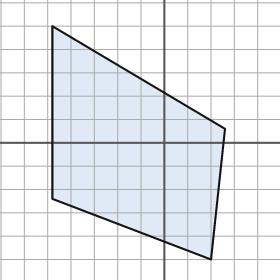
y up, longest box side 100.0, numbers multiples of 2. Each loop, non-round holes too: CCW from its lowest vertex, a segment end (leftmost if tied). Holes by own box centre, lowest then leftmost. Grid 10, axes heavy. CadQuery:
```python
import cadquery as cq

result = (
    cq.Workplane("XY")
    .moveTo(20.0, -50.0)
    .lineTo(26.0, 6.0)
    .lineTo(-48.0, 50.0)
    .lineTo(-48.0, -24.0)
    .close()
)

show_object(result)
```